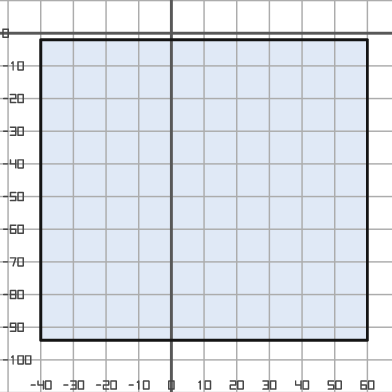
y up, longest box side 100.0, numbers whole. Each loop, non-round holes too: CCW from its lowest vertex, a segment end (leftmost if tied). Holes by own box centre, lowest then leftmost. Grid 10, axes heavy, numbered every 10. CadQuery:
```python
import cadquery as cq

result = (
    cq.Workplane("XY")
    .moveTo(-40.0, -94.0)
    .lineTo(60.0, -94.0)
    .lineTo(60.0, -2.0)
    .lineTo(-40.0, -2.0)
    .close()
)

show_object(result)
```